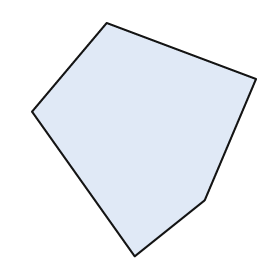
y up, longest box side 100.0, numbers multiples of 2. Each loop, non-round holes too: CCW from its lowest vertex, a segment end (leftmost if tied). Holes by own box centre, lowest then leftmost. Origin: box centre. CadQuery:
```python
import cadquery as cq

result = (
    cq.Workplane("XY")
    .moveTo(-4.0, -50.0)
    .lineTo(26.0, -26.0)
    .lineTo(48.0, 26.0)
    .lineTo(-16.0, 50.0)
    .lineTo(-48.0, 12.0)
    .close()
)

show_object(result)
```